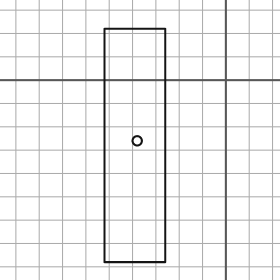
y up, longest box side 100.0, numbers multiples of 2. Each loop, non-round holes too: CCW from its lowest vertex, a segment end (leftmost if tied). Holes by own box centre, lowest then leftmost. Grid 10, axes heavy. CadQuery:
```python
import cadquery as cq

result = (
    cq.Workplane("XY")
    .moveTo(-52.0, -78.0)
    .lineTo(-26.0, -78.0)
    .lineTo(-26.0, 22.0)
    .lineTo(-52.0, 22.0)
    .close()
    .moveTo(-38.0, -26.0)
    .circle(2.0)
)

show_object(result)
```